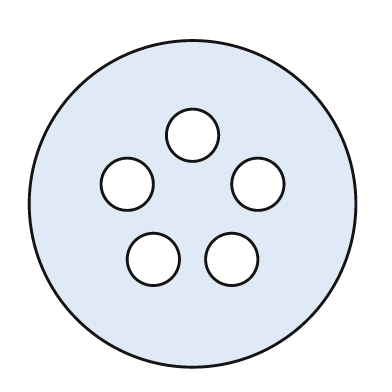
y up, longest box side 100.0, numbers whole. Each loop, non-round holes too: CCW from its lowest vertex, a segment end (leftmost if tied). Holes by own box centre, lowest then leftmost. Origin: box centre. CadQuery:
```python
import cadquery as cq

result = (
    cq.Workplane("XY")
    .moveTo(0.0, 0.0)
    .circle(50.0)
    .moveTo(-12.0, -17.0)
    .circle(8.0)
    .moveTo(12.0, -17.0)
    .circle(8.0)
    .moveTo(-20.0, 6.0)
    .circle(8.0)
    .moveTo(20.0, 6.0)
    .circle(8.0)
    .moveTo(0.0, 21.0)
    .circle(8.0)
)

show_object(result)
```